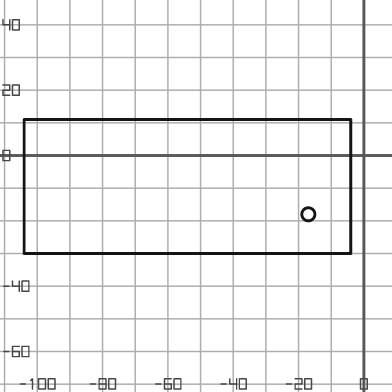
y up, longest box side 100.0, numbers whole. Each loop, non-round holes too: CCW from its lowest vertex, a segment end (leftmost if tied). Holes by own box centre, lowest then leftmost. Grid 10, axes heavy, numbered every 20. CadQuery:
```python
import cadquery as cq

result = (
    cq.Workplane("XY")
    .moveTo(-104.0, -30.0)
    .lineTo(-4.0, -30.0)
    .lineTo(-4.0, 11.0)
    .lineTo(-104.0, 11.0)
    .close()
    .moveTo(-17.0, -18.0)
    .circle(2.0)
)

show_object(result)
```